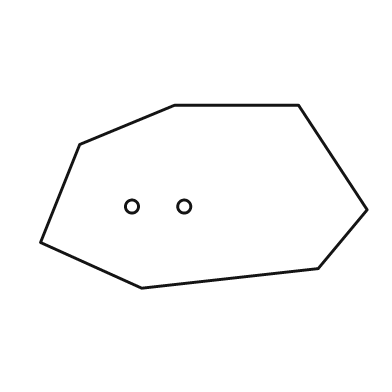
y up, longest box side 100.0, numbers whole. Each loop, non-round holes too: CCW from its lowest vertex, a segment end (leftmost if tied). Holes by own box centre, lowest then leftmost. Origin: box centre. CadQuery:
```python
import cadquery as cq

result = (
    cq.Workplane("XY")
    .moveTo(-19.0, -28.0)
    .lineTo(35.0, -22.0)
    .lineTo(50.0, -4.0)
    .lineTo(29.0, 28.0)
    .lineTo(-9.0, 28.0)
    .lineTo(-38.0, 16.0)
    .lineTo(-50.0, -14.0)
    .close()
    .moveTo(-22.0, -3.0)
    .circle(2.0)
    .moveTo(-6.0, -3.0)
    .circle(2.0)
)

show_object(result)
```